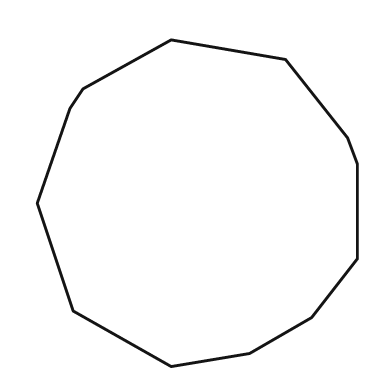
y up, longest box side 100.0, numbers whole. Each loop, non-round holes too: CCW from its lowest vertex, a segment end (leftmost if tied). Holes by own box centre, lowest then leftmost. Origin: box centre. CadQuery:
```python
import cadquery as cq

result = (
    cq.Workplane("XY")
    .moveTo(-8.0, -50.0)
    .lineTo(16.0, -46.0)
    .lineTo(35.0, -35.0)
    .lineTo(49.0, -17.0)
    .lineTo(49.0, 12.0)
    .lineTo(46.0, 20.0)
    .lineTo(27.0, 44.0)
    .lineTo(-8.0, 50.0)
    .lineTo(-35.0, 35.0)
    .lineTo(-39.0, 29.0)
    .lineTo(-49.0, 0.0)
    .lineTo(-38.0, -33.0)
    .close()
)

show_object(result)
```